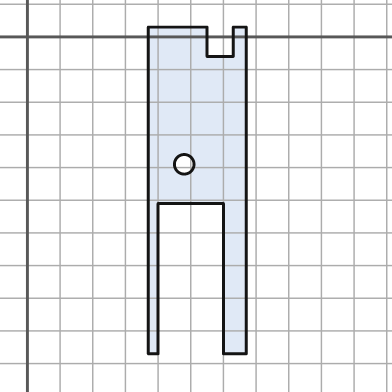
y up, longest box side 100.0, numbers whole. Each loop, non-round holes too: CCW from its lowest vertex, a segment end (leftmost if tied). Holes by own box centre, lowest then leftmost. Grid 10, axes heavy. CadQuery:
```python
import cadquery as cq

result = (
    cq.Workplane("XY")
    .moveTo(37.0, -97.0)
    .lineTo(40.0, -97.0)
    .lineTo(40.0, -51.0)
    .lineTo(60.0, -51.0)
    .lineTo(60.0, -97.0)
    .lineTo(67.0, -97.0)
    .lineTo(67.0, 3.0)
    .lineTo(63.0, 3.0)
    .lineTo(63.0, -6.0)
    .lineTo(55.0, -6.0)
    .lineTo(55.0, 3.0)
    .lineTo(37.0, 3.0)
    .close()
    .moveTo(48.0, -39.0)
    .circle(3.0)
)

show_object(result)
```